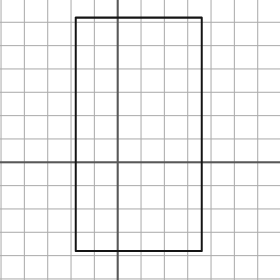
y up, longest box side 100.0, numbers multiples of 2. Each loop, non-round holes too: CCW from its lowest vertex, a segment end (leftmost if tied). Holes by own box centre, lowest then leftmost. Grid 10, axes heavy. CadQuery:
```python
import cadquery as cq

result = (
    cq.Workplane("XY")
    .moveTo(-18.0, -38.0)
    .lineTo(36.0, -38.0)
    .lineTo(36.0, 62.0)
    .lineTo(-18.0, 62.0)
    .close()
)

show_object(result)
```